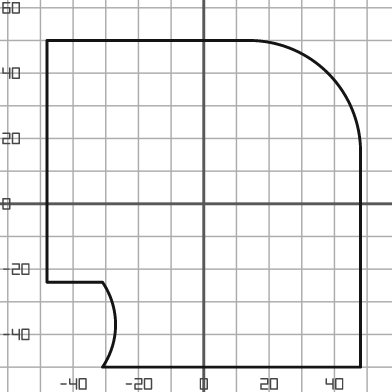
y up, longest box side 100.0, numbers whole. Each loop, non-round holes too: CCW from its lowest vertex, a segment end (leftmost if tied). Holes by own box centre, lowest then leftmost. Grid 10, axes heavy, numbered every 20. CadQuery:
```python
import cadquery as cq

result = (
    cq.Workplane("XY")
    .moveTo(-31.0, -50.0)
    .lineTo(48.0, -50.0)
    .lineTo(48.0, 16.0)
    .threePointArc((38.0, 40.0), (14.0, 50.0))
    .lineTo(-48.0, 50.0)
    .lineTo(-48.0, -24.0)
    .lineTo(-31.0, -24.0)
    .threePointArc((-27.0, -37.0), (-31.0, -50.0))
    .close()
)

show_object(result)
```